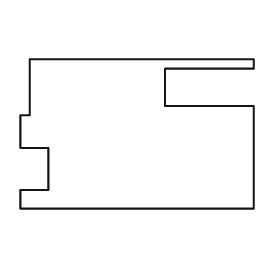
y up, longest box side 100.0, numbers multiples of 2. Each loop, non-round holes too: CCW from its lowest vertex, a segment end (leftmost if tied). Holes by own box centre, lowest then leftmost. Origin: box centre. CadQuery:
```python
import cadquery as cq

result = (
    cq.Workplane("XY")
    .moveTo(-50.0, -32.0)
    .lineTo(50.0, -32.0)
    .lineTo(50.0, 12.0)
    .lineTo(12.0, 12.0)
    .lineTo(12.0, 28.0)
    .lineTo(50.0, 28.0)
    .lineTo(50.0, 32.0)
    .lineTo(-46.0, 32.0)
    .lineTo(-46.0, 8.0)
    .lineTo(-50.0, 8.0)
    .lineTo(-50.0, -6.0)
    .lineTo(-38.0, -6.0)
    .lineTo(-38.0, -24.0)
    .lineTo(-50.0, -24.0)
    .close()
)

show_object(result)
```